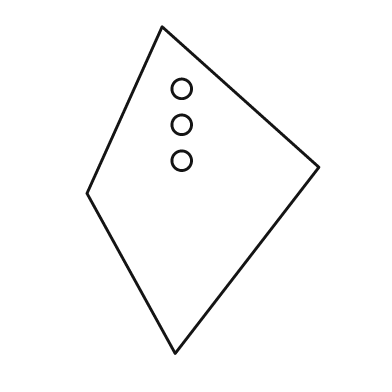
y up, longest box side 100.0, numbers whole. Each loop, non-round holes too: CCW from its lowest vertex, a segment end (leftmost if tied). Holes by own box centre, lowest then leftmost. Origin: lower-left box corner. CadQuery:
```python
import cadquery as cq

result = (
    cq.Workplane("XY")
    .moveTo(27.0, 0.0)
    .lineTo(71.0, 57.0)
    .lineTo(23.0, 100.0)
    .lineTo(0.0, 49.0)
    .close()
    .moveTo(29.0, 59.0)
    .circle(3.0)
    .moveTo(29.0, 70.0)
    .circle(3.0)
    .moveTo(29.0, 81.0)
    .circle(3.0)
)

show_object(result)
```